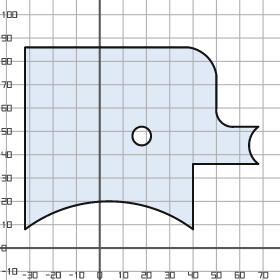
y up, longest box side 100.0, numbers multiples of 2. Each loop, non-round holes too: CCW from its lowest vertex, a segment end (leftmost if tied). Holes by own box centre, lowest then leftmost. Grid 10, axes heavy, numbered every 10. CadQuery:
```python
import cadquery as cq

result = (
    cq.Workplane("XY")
    .moveTo(-32.0, 8.0)
    .threePointArc((4.0, 20.0), (40.0, 8.0))
    .lineTo(40.0, 36.0)
    .lineTo(68.0, 36.0)
    .threePointArc((64.0, 44.0), (68.0, 52.0))
    .lineTo(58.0, 52.0)
    .threePointArc((52.0, 54.0), (50.0, 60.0))
    .lineTo(50.0, 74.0)
    .threePointArc((46.0, 82.0), (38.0, 86.0))
    .lineTo(-32.0, 86.0)
    .close()
    .moveTo(18.0, 48.0)
    .circle(4.0)
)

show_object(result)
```